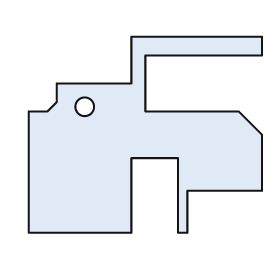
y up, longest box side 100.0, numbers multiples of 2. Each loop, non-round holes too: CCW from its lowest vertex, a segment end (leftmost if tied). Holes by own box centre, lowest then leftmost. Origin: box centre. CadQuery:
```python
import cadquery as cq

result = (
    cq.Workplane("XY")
    .moveTo(-50.0, -42.0)
    .lineTo(-6.0, -42.0)
    .lineTo(-6.0, -10.0)
    .lineTo(14.0, -10.0)
    .lineTo(14.0, -42.0)
    .lineTo(18.0, -42.0)
    .lineTo(18.0, -24.0)
    .lineTo(50.0, -24.0)
    .lineTo(50.0, 0.0)
    .lineTo(40.0, 10.0)
    .lineTo(0.0, 10.0)
    .lineTo(0.0, 34.0)
    .lineTo(50.0, 34.0)
    .lineTo(50.0, 42.0)
    .lineTo(-6.0, 42.0)
    .lineTo(-6.0, 22.0)
    .lineTo(-38.0, 22.0)
    .lineTo(-38.0, 14.0)
    .lineTo(-42.0, 10.0)
    .lineTo(-50.0, 10.0)
    .close()
    .moveTo(-26.0, 12.0)
    .circle(4.0)
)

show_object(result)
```